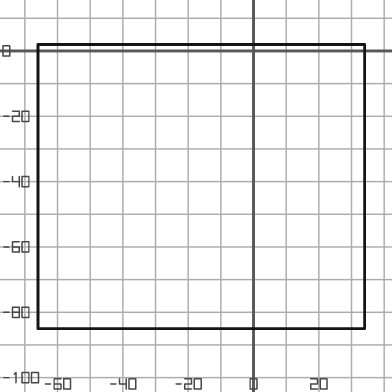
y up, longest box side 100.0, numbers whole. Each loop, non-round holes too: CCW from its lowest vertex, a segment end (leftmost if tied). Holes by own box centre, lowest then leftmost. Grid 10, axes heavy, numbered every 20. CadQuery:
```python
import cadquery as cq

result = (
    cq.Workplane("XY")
    .moveTo(-66.0, -85.0)
    .lineTo(34.0, -85.0)
    .lineTo(34.0, 2.0)
    .lineTo(-66.0, 2.0)
    .close()
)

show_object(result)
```